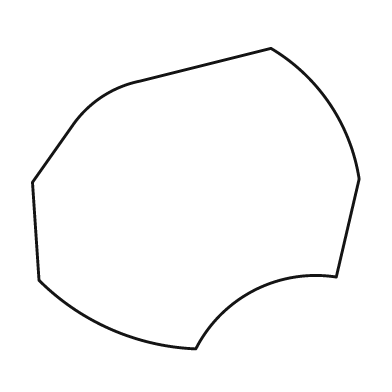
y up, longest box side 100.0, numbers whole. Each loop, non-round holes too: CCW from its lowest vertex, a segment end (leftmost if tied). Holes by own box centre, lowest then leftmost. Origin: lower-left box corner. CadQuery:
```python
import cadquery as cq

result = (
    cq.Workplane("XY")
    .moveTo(50.0, 0.0)
    .threePointArc((68.0, 18.0), (93.0, 22.0))
    .lineTo(100.0, 52.0)
    .threePointArc((91.0, 75.0), (73.0, 92.0))
    .lineTo(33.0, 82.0)
    .threePointArc((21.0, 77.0), (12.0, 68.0))
    .lineTo(0.0, 51.0)
    .lineTo(2.0, 21.0)
    .threePointArc((24.0, 6.0), (50.0, 0.0))
    .close()
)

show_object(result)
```